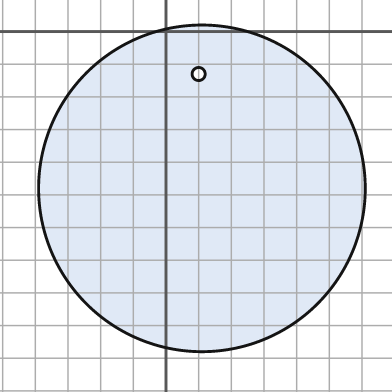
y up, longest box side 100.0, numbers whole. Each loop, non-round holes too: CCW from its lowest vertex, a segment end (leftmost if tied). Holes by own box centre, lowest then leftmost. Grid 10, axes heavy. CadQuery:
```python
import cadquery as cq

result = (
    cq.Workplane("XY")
    .moveTo(11.0, -48.0)
    .circle(50.0)
    .moveTo(10.0, -13.0)
    .circle(2.0)
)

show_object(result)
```